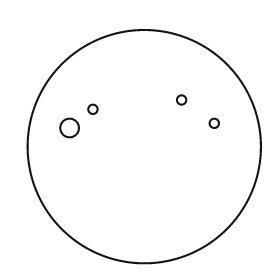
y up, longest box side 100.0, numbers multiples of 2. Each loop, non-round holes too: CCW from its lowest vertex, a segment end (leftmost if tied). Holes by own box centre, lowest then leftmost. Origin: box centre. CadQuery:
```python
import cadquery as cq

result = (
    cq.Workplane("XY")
    .moveTo(0.0, 0.0)
    .circle(50.0)
    .moveTo(-32.0, 8.0)
    .circle(4.0)
    .moveTo(30.0, 10.0)
    .circle(2.0)
    .moveTo(-22.0, 16.0)
    .circle(2.0)
    .moveTo(16.0, 20.0)
    .circle(2.0)
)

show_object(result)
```